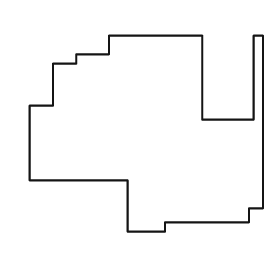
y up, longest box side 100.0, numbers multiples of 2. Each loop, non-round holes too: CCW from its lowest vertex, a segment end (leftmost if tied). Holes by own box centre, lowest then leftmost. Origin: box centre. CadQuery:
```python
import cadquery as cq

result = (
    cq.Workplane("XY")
    .moveTo(-8.0, -42.0)
    .lineTo(8.0, -42.0)
    .lineTo(8.0, -38.0)
    .lineTo(44.0, -38.0)
    .lineTo(44.0, -32.0)
    .lineTo(50.0, -32.0)
    .lineTo(50.0, 42.0)
    .lineTo(46.0, 42.0)
    .lineTo(46.0, 6.0)
    .lineTo(24.0, 6.0)
    .lineTo(24.0, 42.0)
    .lineTo(-16.0, 42.0)
    .lineTo(-16.0, 34.0)
    .lineTo(-30.0, 34.0)
    .lineTo(-30.0, 30.0)
    .lineTo(-40.0, 30.0)
    .lineTo(-40.0, 12.0)
    .lineTo(-50.0, 12.0)
    .lineTo(-50.0, -20.0)
    .lineTo(-8.0, -20.0)
    .close()
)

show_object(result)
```